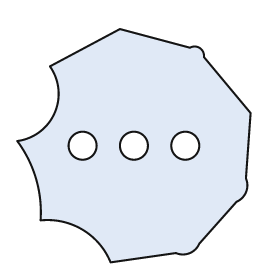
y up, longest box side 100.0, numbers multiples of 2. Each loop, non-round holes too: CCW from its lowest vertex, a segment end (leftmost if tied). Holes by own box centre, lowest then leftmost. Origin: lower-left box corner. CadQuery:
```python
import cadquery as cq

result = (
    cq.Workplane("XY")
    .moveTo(40.0, 0.0)
    .lineTo(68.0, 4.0)
    .threePointArc((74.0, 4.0), (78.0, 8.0))
    .lineTo(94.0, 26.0)
    .threePointArc((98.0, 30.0), (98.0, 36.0))
    .lineTo(100.0, 64.0)
    .lineTo(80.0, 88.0)
    .threePointArc((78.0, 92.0), (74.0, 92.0))
    .lineTo(44.0, 100.0)
    .lineTo(14.0, 84.0)
    .threePointArc((16.0, 64.0), (0.0, 52.0))
    .threePointArc((8.0, 36.0), (10.0, 18.0))
    .threePointArc((28.0, 14.0), (40.0, 0.0))
    .close()
    .moveTo(28.0, 50.0)
    .circle(6.0)
    .moveTo(50.0, 50.0)
    .circle(6.0)
    .moveTo(72.0, 50.0)
    .circle(6.0)
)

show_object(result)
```